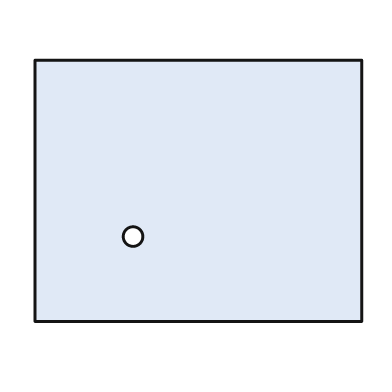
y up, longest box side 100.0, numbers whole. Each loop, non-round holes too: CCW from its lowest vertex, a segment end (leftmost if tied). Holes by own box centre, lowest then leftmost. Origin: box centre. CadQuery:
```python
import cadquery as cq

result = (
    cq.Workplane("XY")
    .moveTo(-50.0, -40.0)
    .lineTo(50.0, -40.0)
    .lineTo(50.0, 40.0)
    .lineTo(-50.0, 40.0)
    .close()
    .moveTo(-20.0, -14.0)
    .circle(3.0)
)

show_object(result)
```